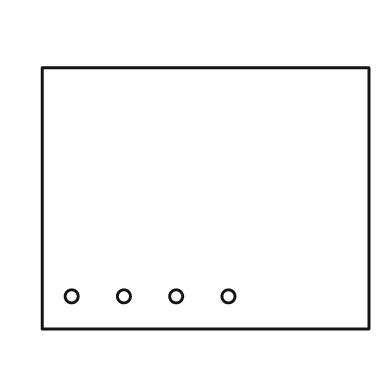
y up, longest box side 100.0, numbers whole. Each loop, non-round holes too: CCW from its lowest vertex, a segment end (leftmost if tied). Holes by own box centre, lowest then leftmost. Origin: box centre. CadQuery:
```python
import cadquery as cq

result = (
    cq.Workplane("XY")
    .moveTo(-50.0, -40.0)
    .lineTo(50.0, -40.0)
    .lineTo(50.0, 40.0)
    .lineTo(-50.0, 40.0)
    .close()
    .moveTo(-41.0, -30.0)
    .circle(2.0)
    .moveTo(-25.0, -30.0)
    .circle(2.0)
    .moveTo(-9.0, -30.0)
    .circle(2.0)
    .moveTo(7.0, -30.0)
    .circle(2.0)
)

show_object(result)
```